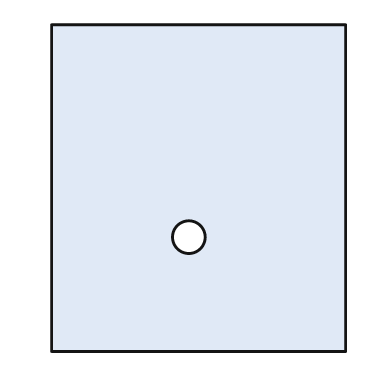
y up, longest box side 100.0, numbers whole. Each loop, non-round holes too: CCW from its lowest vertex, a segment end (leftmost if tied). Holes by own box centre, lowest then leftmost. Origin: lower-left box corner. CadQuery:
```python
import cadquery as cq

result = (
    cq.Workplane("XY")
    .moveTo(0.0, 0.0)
    .lineTo(90.0, 0.0)
    .lineTo(90.0, 100.0)
    .lineTo(0.0, 100.0)
    .close()
    .moveTo(42.0, 35.0)
    .circle(5.0)
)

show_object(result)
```